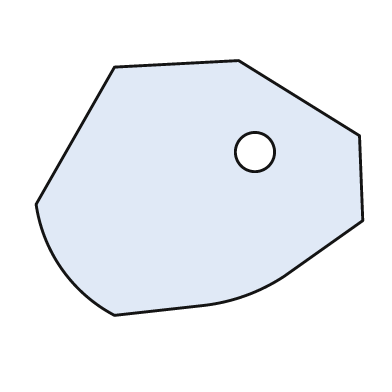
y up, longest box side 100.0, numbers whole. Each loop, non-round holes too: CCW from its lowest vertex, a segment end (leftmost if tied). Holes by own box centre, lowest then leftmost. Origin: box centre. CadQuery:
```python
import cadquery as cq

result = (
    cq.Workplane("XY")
    .moveTo(-26.0, -39.0)
    .lineTo(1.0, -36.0)
    .threePointArc((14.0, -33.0), (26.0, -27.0))
    .lineTo(50.0, -10.0)
    .lineTo(49.0, 16.0)
    .lineTo(12.0, 39.0)
    .lineTo(-26.0, 37.0)
    .lineTo(-50.0, -5.0)
    .threePointArc((-42.0, -25.0), (-26.0, -39.0))
    .close()
    .moveTo(17.0, 11.0)
    .circle(6.0)
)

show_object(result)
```